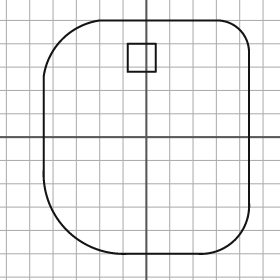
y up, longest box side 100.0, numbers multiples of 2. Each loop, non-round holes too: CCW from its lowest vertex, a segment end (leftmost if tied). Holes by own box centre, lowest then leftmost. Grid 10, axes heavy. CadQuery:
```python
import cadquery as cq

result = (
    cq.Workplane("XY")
    .moveTo(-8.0, -50.0)
    .lineTo(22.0, -50.0)
    .threePointArc((38.0, -44.0), (44.0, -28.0))
    .lineTo(44.0, 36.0)
    .threePointArc((40.0, 46.0), (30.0, 50.0))
    .lineTo(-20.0, 50.0)
    .threePointArc((-36.0, 42.0), (-44.0, 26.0))
    .lineTo(-44.0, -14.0)
    .threePointArc((-34.0, -40.0), (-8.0, -50.0))
    .close()
    .moveTo(-8.0, 28.0)
    .lineTo(4.0, 28.0)
    .lineTo(4.0, 40.0)
    .lineTo(-8.0, 40.0)
    .close()
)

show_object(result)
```